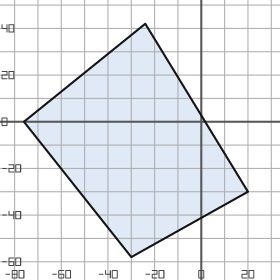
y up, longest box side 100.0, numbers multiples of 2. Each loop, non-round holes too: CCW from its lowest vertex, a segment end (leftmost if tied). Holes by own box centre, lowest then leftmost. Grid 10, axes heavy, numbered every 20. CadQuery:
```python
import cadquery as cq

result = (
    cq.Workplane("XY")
    .moveTo(-30.0, -58.0)
    .lineTo(20.0, -30.0)
    .lineTo(-24.0, 42.0)
    .lineTo(-76.0, 0.0)
    .close()
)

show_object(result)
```